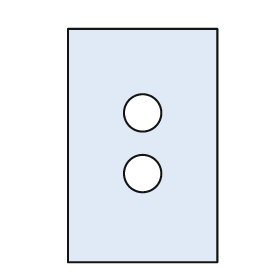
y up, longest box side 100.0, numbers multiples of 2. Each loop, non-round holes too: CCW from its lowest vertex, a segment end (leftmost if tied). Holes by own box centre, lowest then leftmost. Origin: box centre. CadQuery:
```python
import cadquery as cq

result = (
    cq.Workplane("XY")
    .moveTo(-32.0, -50.0)
    .lineTo(32.0, -50.0)
    .lineTo(32.0, 50.0)
    .lineTo(-32.0, 50.0)
    .close()
    .moveTo(0.0, -12.0)
    .circle(8.0)
    .moveTo(0.0, 14.0)
    .circle(8.0)
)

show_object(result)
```